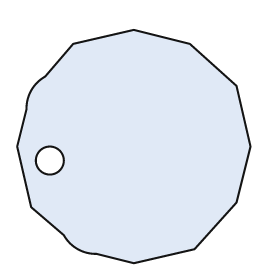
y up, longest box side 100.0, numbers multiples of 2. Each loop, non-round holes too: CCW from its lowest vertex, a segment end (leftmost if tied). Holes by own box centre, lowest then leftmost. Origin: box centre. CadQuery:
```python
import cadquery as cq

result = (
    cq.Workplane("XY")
    .moveTo(0.0, -50.0)
    .lineTo(26.0, -44.0)
    .lineTo(44.0, -24.0)
    .lineTo(50.0, 0.0)
    .lineTo(44.0, 26.0)
    .lineTo(24.0, 44.0)
    .lineTo(0.0, 50.0)
    .lineTo(-26.0, 44.0)
    .lineTo(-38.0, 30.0)
    .threePointArc((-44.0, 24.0), (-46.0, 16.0))
    .lineTo(-50.0, 0.0)
    .lineTo(-44.0, -26.0)
    .lineTo(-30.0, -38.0)
    .threePointArc((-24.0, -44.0), (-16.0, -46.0))
    .close()
    .moveTo(-36.0, -6.0)
    .circle(6.0)
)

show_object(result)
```